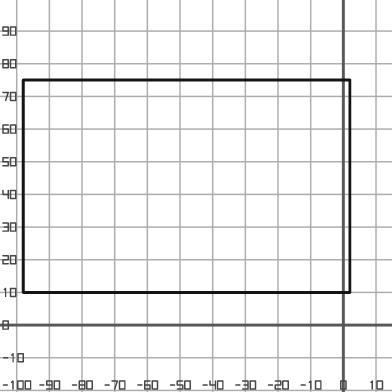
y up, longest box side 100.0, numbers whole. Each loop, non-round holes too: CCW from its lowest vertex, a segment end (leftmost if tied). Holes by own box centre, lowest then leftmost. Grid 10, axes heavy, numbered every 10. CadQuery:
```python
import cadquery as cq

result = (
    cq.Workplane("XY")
    .moveTo(-98.0, 10.0)
    .lineTo(2.0, 10.0)
    .lineTo(2.0, 75.0)
    .lineTo(-98.0, 75.0)
    .close()
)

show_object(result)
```